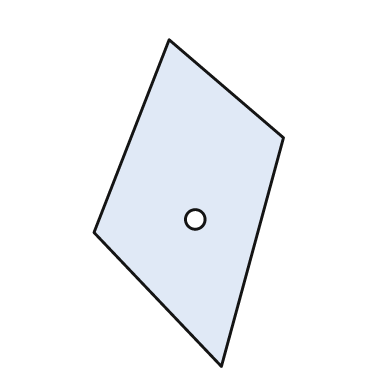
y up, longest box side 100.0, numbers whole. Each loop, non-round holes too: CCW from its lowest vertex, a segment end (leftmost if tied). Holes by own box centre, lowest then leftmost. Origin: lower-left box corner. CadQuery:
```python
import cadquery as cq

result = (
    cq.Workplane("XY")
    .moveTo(39.0, 0.0)
    .lineTo(58.0, 70.0)
    .lineTo(23.0, 100.0)
    .lineTo(0.0, 41.0)
    .close()
    .moveTo(31.0, 45.0)
    .circle(3.0)
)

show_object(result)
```